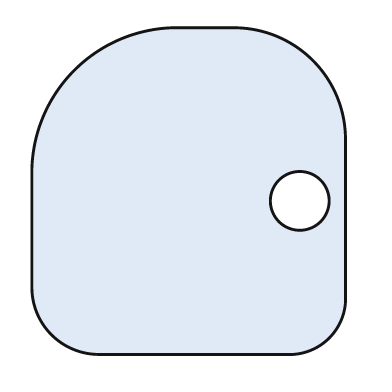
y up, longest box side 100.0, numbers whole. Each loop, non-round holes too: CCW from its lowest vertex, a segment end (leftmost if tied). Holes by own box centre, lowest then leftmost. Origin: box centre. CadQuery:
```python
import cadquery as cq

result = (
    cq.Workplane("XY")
    .moveTo(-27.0, -50.0)
    .lineTo(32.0, -50.0)
    .threePointArc((43.0, -45.0), (48.0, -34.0))
    .lineTo(48.0, 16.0)
    .threePointArc((38.0, 40.0), (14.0, 50.0))
    .lineTo(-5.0, 50.0)
    .threePointArc((-35.0, 37.0), (-48.0, 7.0))
    .lineTo(-48.0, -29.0)
    .threePointArc((-42.0, -44.0), (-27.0, -50.0))
    .close()
    .moveTo(34.0, -3.0)
    .circle(9.0)
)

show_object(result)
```